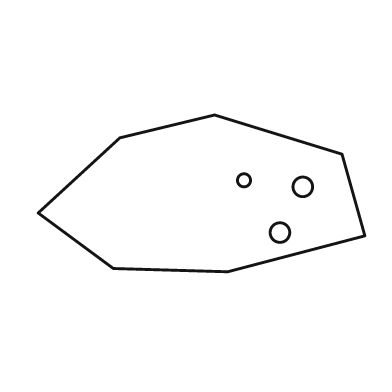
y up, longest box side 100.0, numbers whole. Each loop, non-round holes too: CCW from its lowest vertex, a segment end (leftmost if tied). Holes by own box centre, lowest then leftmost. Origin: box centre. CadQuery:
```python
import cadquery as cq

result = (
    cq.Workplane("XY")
    .moveTo(8.0, -24.0)
    .lineTo(50.0, -13.0)
    .lineTo(43.0, 12.0)
    .lineTo(4.0, 24.0)
    .lineTo(-25.0, 17.0)
    .lineTo(-50.0, -6.0)
    .lineTo(-27.0, -23.0)
    .close()
    .moveTo(24.0, -12.0)
    .circle(3.0)
    .moveTo(31.0, 2.0)
    .circle(3.0)
    .moveTo(13.0, 4.0)
    .circle(2.0)
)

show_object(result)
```